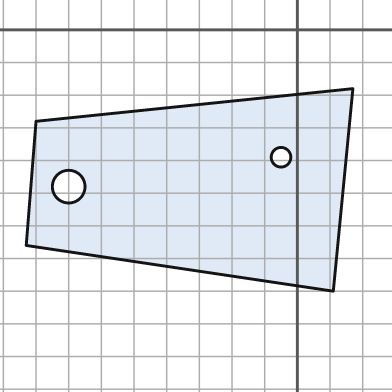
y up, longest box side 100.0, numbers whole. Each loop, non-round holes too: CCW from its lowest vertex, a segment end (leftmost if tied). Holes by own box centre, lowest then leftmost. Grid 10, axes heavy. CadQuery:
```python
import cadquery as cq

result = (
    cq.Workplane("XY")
    .moveTo(11.0, -80.0)
    .lineTo(17.0, -18.0)
    .lineTo(-80.0, -28.0)
    .lineTo(-83.0, -66.0)
    .close()
    .moveTo(-70.0, -48.0)
    .circle(5.0)
    .moveTo(-5.0, -39.0)
    .circle(3.0)
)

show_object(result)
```